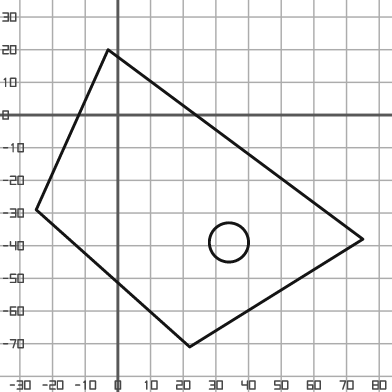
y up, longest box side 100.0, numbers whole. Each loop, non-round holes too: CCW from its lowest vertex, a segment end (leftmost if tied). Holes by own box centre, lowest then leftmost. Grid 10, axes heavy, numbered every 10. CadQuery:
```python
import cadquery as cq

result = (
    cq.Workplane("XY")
    .moveTo(22.0, -71.0)
    .lineTo(75.0, -38.0)
    .lineTo(-3.0, 20.0)
    .lineTo(-25.0, -29.0)
    .close()
    .moveTo(34.0, -39.0)
    .circle(6.0)
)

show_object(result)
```